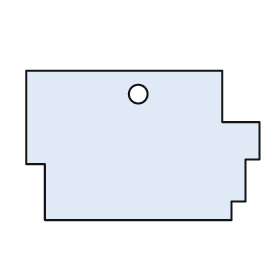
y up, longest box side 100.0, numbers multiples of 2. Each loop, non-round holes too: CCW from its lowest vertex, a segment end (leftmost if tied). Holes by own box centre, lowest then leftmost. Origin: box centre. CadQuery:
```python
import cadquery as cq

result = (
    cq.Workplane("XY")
    .moveTo(-42.0, -32.0)
    .lineTo(38.0, -32.0)
    .lineTo(38.0, -24.0)
    .lineTo(44.0, -24.0)
    .lineTo(44.0, -6.0)
    .lineTo(50.0, -6.0)
    .lineTo(50.0, 10.0)
    .lineTo(34.0, 10.0)
    .lineTo(34.0, 32.0)
    .lineTo(-50.0, 32.0)
    .lineTo(-50.0, -8.0)
    .lineTo(-42.0, -8.0)
    .close()
    .moveTo(-2.0, 22.0)
    .circle(4.0)
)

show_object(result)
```